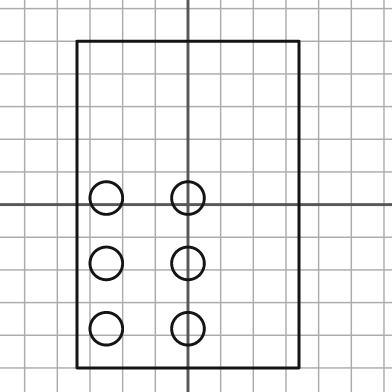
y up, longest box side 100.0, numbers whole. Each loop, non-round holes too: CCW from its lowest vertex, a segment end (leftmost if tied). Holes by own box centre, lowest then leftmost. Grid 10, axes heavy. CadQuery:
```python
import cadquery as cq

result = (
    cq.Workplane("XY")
    .moveTo(-34.0, -50.0)
    .lineTo(34.0, -50.0)
    .lineTo(34.0, 50.0)
    .lineTo(-34.0, 50.0)
    .close()
    .moveTo(-25.0, -38.0)
    .circle(5.0)
    .moveTo(0.0, -38.0)
    .circle(5.0)
    .moveTo(-25.0, -18.0)
    .circle(5.0)
    .moveTo(0.0, -18.0)
    .circle(5.0)
    .moveTo(-25.0, 2.0)
    .circle(5.0)
    .moveTo(0.0, 2.0)
    .circle(5.0)
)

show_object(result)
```